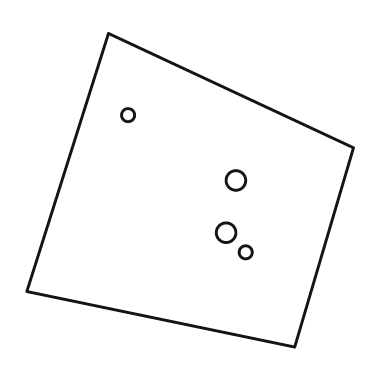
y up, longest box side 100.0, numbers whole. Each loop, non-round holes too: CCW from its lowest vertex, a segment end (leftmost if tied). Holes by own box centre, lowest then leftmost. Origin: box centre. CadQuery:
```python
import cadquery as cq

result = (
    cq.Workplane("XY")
    .moveTo(32.0, -48.0)
    .lineTo(50.0, 13.0)
    .lineTo(-25.0, 48.0)
    .lineTo(-50.0, -31.0)
    .close()
    .moveTo(17.0, -19.0)
    .circle(2.0)
    .moveTo(11.0, -13.0)
    .circle(3.0)
    .moveTo(14.0, 3.0)
    .circle(3.0)
    .moveTo(-19.0, 23.0)
    .circle(2.0)
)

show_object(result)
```